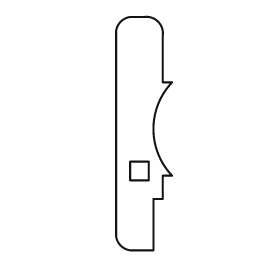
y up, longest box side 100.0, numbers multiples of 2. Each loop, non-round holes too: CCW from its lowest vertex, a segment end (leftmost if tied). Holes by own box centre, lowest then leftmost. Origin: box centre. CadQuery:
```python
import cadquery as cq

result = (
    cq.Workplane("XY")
    .moveTo(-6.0, -50.0)
    .lineTo(4.0, -50.0)
    .lineTo(4.0, -28.0)
    .lineTo(8.0, -28.0)
    .lineTo(8.0, -18.0)
    .lineTo(12.0, -18.0)
    .threePointArc((4.0, 2.0), (12.0, 22.0))
    .lineTo(8.0, 22.0)
    .lineTo(8.0, 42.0)
    .threePointArc((6.0, 48.0), (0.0, 50.0))
    .lineTo(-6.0, 50.0)
    .threePointArc((-10.0, 48.0), (-12.0, 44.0))
    .lineTo(-12.0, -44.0)
    .threePointArc((-10.0, -48.0), (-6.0, -50.0))
    .close()
    .moveTo(-6.0, -20.0)
    .lineTo(2.0, -20.0)
    .lineTo(2.0, -12.0)
    .lineTo(-6.0, -12.0)
    .close()
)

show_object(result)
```